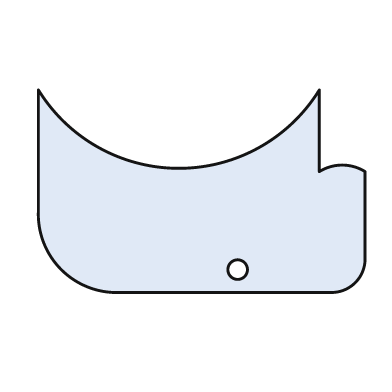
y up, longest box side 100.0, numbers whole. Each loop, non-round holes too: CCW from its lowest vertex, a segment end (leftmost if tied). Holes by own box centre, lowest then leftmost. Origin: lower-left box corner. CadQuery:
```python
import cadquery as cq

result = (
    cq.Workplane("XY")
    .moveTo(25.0, 0.0)
    .lineTo(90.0, 0.0)
    .threePointArc((97.0, 3.0), (100.0, 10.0))
    .lineTo(100.0, 37.0)
    .threePointArc((93.0, 39.0), (86.0, 37.0))
    .lineTo(86.0, 62.0)
    .threePointArc((43.0, 38.0), (0.0, 62.0))
    .lineTo(0.0, 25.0)
    .threePointArc((7.0, 7.0), (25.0, 0.0))
    .close()
    .moveTo(61.0, 7.0)
    .circle(3.0)
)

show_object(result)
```